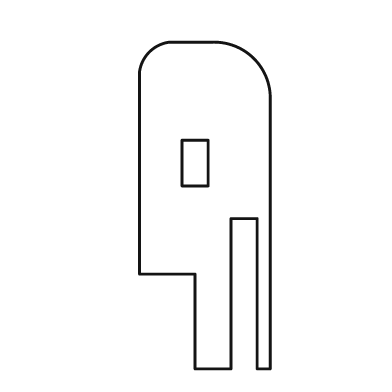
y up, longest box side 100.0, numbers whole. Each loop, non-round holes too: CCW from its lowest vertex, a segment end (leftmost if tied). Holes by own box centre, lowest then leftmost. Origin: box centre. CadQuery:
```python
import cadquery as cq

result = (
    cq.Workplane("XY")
    .moveTo(-3.0, -50.0)
    .lineTo(8.0, -50.0)
    .lineTo(8.0, -4.0)
    .lineTo(16.0, -4.0)
    .lineTo(16.0, -50.0)
    .lineTo(20.0, -50.0)
    .lineTo(20.0, 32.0)
    .threePointArc((15.0, 45.0), (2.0, 50.0))
    .lineTo(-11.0, 50.0)
    .threePointArc((-17.0, 47.0), (-20.0, 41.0))
    .lineTo(-20.0, -21.0)
    .lineTo(-3.0, -21.0)
    .close()
    .moveTo(-7.0, 6.0)
    .lineTo(1.0, 6.0)
    .lineTo(1.0, 20.0)
    .lineTo(-7.0, 20.0)
    .close()
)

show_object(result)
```